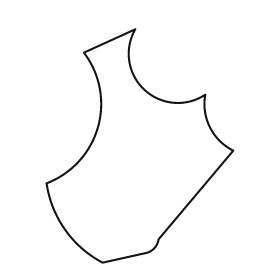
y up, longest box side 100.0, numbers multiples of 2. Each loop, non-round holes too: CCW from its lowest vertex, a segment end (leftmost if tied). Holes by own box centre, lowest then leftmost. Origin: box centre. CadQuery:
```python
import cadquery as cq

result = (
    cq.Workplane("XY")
    .moveTo(-16.0, -50.0)
    .lineTo(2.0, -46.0)
    .threePointArc((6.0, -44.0), (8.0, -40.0))
    .lineTo(40.0, -2.0)
    .threePointArc((30.0, 8.0), (28.0, 22.0))
    .threePointArc((2.0, 24.0), (-2.0, 50.0))
    .lineTo(-24.0, 40.0)
    .threePointArc((-18.0, 8.0), (-40.0, -16.0))
    .threePointArc((-32.0, -36.0), (-16.0, -50.0))
    .close()
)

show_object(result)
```